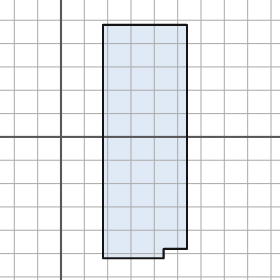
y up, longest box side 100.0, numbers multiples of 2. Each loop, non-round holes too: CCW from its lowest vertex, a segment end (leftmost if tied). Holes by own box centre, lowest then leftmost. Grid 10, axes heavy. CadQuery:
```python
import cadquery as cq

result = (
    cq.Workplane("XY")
    .moveTo(18.0, -52.0)
    .lineTo(44.0, -52.0)
    .lineTo(44.0, -48.0)
    .lineTo(54.0, -48.0)
    .lineTo(54.0, 48.0)
    .lineTo(18.0, 48.0)
    .close()
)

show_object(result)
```